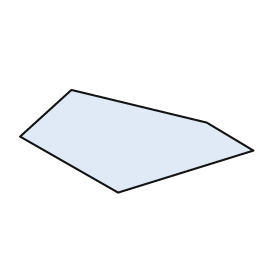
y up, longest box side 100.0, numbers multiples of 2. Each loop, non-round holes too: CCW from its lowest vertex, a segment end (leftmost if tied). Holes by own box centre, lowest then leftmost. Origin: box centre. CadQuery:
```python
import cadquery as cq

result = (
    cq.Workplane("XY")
    .moveTo(-8.0, -22.0)
    .lineTo(50.0, -4.0)
    .lineTo(30.0, 8.0)
    .lineTo(-28.0, 22.0)
    .lineTo(-50.0, 2.0)
    .close()
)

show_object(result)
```